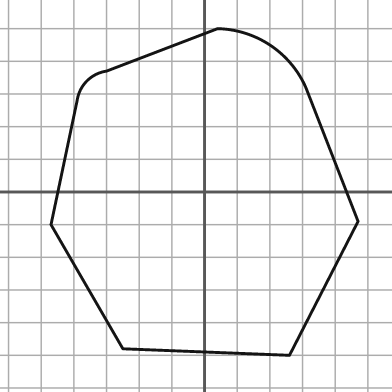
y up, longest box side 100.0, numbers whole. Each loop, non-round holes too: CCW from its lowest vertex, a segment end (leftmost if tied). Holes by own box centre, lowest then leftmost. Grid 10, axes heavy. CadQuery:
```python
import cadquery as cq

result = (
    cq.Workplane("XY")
    .moveTo(26.0, -50.0)
    .lineTo(47.0, -9.0)
    .lineTo(31.0, 32.0)
    .threePointArc((20.0, 45.0), (4.0, 50.0))
    .lineTo(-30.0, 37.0)
    .threePointArc((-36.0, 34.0), (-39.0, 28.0))
    .lineTo(-47.0, -10.0)
    .lineTo(-25.0, -48.0)
    .close()
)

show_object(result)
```